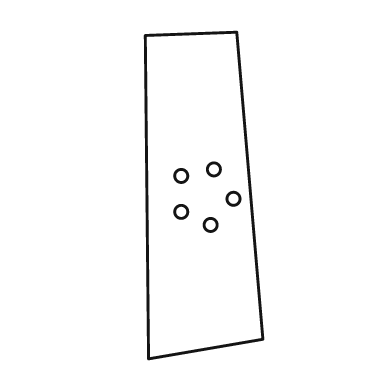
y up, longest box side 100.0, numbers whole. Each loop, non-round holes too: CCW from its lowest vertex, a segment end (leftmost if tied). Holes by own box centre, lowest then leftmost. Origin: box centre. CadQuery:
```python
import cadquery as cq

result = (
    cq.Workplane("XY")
    .moveTo(-17.0, -50.0)
    .lineTo(18.0, -44.0)
    .lineTo(10.0, 50.0)
    .lineTo(-18.0, 49.0)
    .close()
    .moveTo(2.0, -9.0)
    .circle(2.0)
    .moveTo(-7.0, -5.0)
    .circle(2.0)
    .moveTo(9.0, -1.0)
    .circle(2.0)
    .moveTo(-7.0, 6.0)
    .circle(2.0)
    .moveTo(3.0, 8.0)
    .circle(2.0)
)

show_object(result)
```